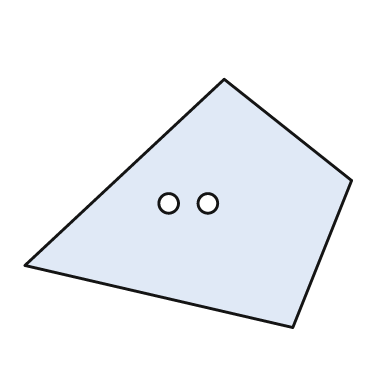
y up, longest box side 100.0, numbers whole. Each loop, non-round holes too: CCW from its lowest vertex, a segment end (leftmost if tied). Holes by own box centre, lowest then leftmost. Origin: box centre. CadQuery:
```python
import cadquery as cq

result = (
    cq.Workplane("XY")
    .moveTo(32.0, -38.0)
    .lineTo(50.0, 7.0)
    .lineTo(11.0, 38.0)
    .lineTo(-50.0, -19.0)
    .close()
    .moveTo(-6.0, 0.0)
    .circle(3.0)
    .moveTo(6.0, 0.0)
    .circle(3.0)
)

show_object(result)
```